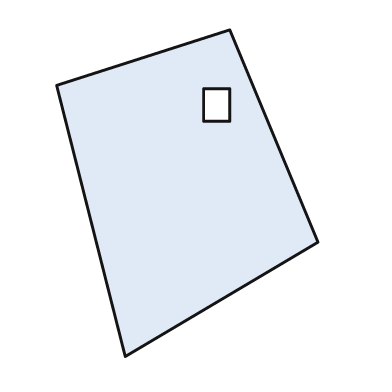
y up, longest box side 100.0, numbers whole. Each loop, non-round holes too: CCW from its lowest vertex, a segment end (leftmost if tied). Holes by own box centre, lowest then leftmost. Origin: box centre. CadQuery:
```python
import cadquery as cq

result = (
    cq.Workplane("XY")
    .moveTo(-19.0, -50.0)
    .lineTo(40.0, -15.0)
    .lineTo(13.0, 50.0)
    .lineTo(-40.0, 33.0)
    .close()
    .moveTo(5.0, 22.0)
    .lineTo(13.0, 22.0)
    .lineTo(13.0, 32.0)
    .lineTo(5.0, 32.0)
    .close()
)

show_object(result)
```